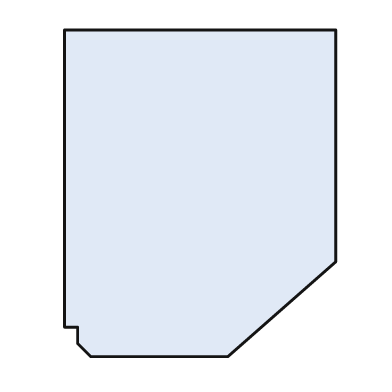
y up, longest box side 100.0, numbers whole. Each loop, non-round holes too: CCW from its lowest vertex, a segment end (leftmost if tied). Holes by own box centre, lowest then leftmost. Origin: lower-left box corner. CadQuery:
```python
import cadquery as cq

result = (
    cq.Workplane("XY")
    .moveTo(8.0, 0.0)
    .lineTo(50.0, 0.0)
    .lineTo(83.0, 29.0)
    .lineTo(83.0, 100.0)
    .lineTo(0.0, 100.0)
    .lineTo(0.0, 9.0)
    .lineTo(4.0, 9.0)
    .lineTo(4.0, 4.0)
    .close()
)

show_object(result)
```